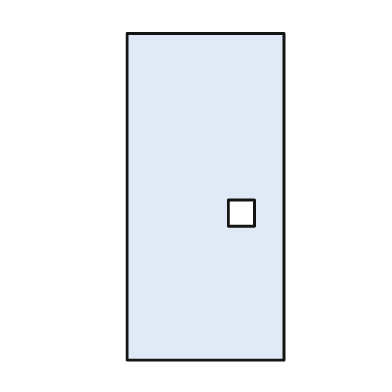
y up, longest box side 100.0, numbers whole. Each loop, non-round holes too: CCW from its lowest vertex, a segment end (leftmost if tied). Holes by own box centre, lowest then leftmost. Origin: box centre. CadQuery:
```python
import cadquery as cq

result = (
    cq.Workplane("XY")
    .moveTo(-24.0, -50.0)
    .lineTo(24.0, -50.0)
    .lineTo(24.0, 50.0)
    .lineTo(-24.0, 50.0)
    .close()
    .moveTo(7.0, -9.0)
    .lineTo(15.0, -9.0)
    .lineTo(15.0, -1.0)
    .lineTo(7.0, -1.0)
    .close()
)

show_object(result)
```